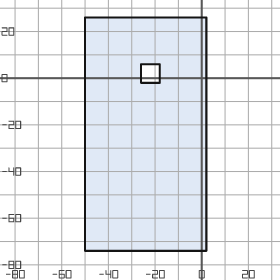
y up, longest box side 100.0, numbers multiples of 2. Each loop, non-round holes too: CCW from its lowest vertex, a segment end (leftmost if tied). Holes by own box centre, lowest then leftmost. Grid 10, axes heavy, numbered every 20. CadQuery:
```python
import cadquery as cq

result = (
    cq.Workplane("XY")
    .moveTo(-50.0, -74.0)
    .lineTo(2.0, -74.0)
    .lineTo(2.0, 26.0)
    .lineTo(-50.0, 26.0)
    .close()
    .moveTo(-26.0, -2.0)
    .lineTo(-18.0, -2.0)
    .lineTo(-18.0, 6.0)
    .lineTo(-26.0, 6.0)
    .close()
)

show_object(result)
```